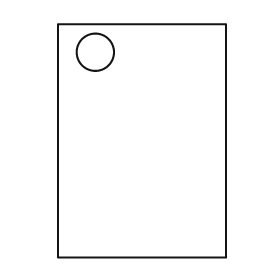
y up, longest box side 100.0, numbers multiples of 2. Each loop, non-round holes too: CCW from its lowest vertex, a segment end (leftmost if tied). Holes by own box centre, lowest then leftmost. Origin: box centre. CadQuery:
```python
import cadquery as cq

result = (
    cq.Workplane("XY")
    .moveTo(-36.0, -50.0)
    .lineTo(36.0, -50.0)
    .lineTo(36.0, 50.0)
    .lineTo(-36.0, 50.0)
    .close()
    .moveTo(-20.0, 38.0)
    .circle(8.0)
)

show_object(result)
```